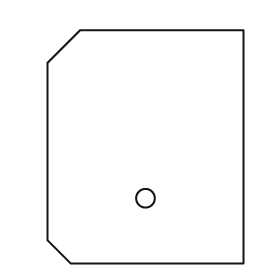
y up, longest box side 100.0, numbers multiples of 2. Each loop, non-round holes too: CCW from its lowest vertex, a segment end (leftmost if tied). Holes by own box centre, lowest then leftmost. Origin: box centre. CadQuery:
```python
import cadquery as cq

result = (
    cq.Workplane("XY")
    .moveTo(-32.0, -50.0)
    .lineTo(42.0, -50.0)
    .lineTo(42.0, 50.0)
    .lineTo(-28.0, 50.0)
    .lineTo(-42.0, 36.0)
    .lineTo(-42.0, -40.0)
    .close()
    .moveTo(0.0, -22.0)
    .circle(4.0)
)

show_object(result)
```